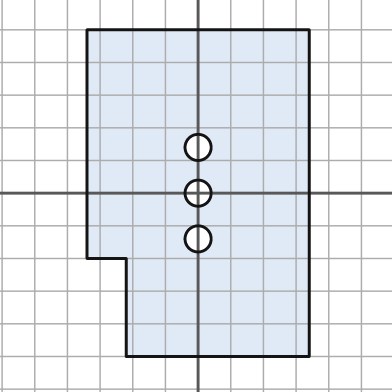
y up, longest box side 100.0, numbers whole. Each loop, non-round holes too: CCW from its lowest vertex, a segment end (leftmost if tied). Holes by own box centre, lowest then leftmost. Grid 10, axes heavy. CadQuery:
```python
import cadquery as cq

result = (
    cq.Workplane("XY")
    .moveTo(-22.0, -50.0)
    .lineTo(34.0, -50.0)
    .lineTo(34.0, 50.0)
    .lineTo(-34.0, 50.0)
    .lineTo(-34.0, -20.0)
    .lineTo(-22.0, -20.0)
    .close()
    .moveTo(0.0, -14.0)
    .circle(4.0)
    .moveTo(0.0, 0.0)
    .circle(4.0)
    .moveTo(0.0, 14.0)
    .circle(4.0)
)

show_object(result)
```